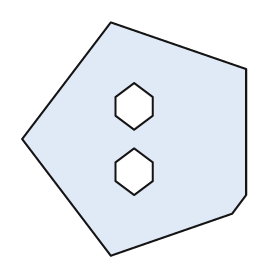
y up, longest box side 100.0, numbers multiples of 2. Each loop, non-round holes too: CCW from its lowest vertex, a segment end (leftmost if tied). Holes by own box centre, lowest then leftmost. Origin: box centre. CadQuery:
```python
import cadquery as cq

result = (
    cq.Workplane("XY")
    .moveTo(-10.0, -50.0)
    .lineTo(42.0, -32.0)
    .lineTo(48.0, -24.0)
    .lineTo(48.0, 30.0)
    .lineTo(-10.0, 50.0)
    .lineTo(-48.0, 0.0)
    .close()
    .moveTo(0.0, -24.0)
    .lineTo(8.0, -18.0)
    .lineTo(8.0, -10.0)
    .lineTo(0.0, -4.0)
    .lineTo(-8.0, -10.0)
    .lineTo(-8.0, -18.0)
    .close()
    .moveTo(0.0, 4.0)
    .lineTo(8.0, 10.0)
    .lineTo(8.0, 18.0)
    .lineTo(0.0, 24.0)
    .lineTo(-8.0, 18.0)
    .lineTo(-8.0, 10.0)
    .close()
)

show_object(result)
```